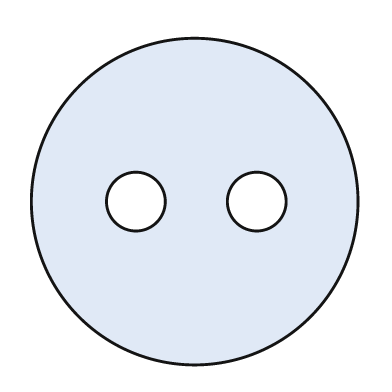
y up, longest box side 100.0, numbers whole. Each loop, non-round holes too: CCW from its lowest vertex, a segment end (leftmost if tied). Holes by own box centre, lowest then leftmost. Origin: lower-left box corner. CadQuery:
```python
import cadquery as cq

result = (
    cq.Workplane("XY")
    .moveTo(50.0, 50.0)
    .circle(50.0)
    .moveTo(32.0, 50.0)
    .circle(9.0)
    .moveTo(69.0, 50.0)
    .circle(9.0)
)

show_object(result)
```